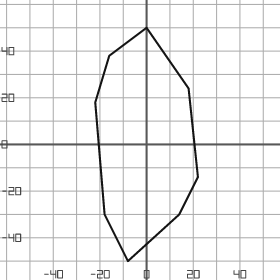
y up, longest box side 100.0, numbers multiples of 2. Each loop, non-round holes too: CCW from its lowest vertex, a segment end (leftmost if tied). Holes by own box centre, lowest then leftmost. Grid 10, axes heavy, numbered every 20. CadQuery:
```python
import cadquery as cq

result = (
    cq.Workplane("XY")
    .moveTo(-8.0, -50.0)
    .lineTo(14.0, -30.0)
    .lineTo(22.0, -14.0)
    .lineTo(18.0, 24.0)
    .lineTo(0.0, 50.0)
    .lineTo(-16.0, 38.0)
    .lineTo(-22.0, 18.0)
    .lineTo(-18.0, -30.0)
    .close()
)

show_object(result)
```